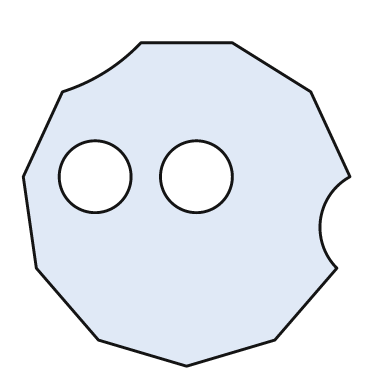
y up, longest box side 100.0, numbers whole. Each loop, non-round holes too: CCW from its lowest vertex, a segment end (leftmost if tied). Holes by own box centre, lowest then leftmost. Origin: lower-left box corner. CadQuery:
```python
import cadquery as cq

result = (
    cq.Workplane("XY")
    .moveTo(50.0, 0.0)
    .lineTo(77.0, 8.0)
    .lineTo(96.0, 30.0)
    .threePointArc((91.0, 45.0), (100.0, 58.0))
    .lineTo(88.0, 84.0)
    .lineTo(64.0, 99.0)
    .lineTo(36.0, 99.0)
    .threePointArc((25.0, 90.0), (12.0, 84.0))
    .lineTo(0.0, 58.0)
    .lineTo(4.0, 30.0)
    .lineTo(23.0, 8.0)
    .close()
    .moveTo(22.0, 58.0)
    .circle(11.0)
    .moveTo(53.0, 58.0)
    .circle(11.0)
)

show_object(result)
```